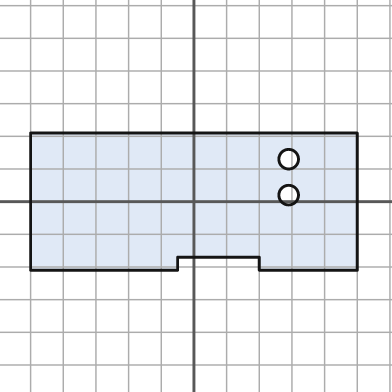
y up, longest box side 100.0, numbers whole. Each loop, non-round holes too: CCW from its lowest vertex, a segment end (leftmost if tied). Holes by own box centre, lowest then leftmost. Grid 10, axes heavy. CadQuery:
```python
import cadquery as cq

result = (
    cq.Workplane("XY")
    .moveTo(-50.0, -21.0)
    .lineTo(-5.0, -21.0)
    .lineTo(-5.0, -17.0)
    .lineTo(20.0, -17.0)
    .lineTo(20.0, -21.0)
    .lineTo(50.0, -21.0)
    .lineTo(50.0, 21.0)
    .lineTo(-50.0, 21.0)
    .close()
    .moveTo(29.0, 2.0)
    .circle(3.0)
    .moveTo(29.0, 13.0)
    .circle(3.0)
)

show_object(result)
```